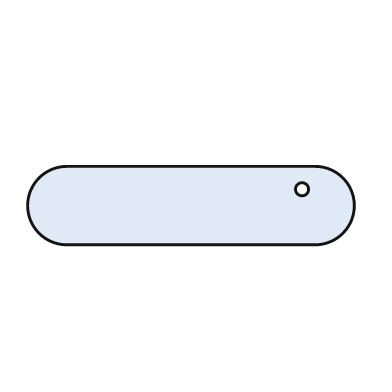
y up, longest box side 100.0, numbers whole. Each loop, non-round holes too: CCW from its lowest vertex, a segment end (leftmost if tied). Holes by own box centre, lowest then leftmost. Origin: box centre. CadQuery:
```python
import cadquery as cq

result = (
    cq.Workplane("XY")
    .moveTo(-38.0, -12.0)
    .lineTo(38.0, -12.0)
    .threePointArc((50.0, 0.0), (38.0, 12.0))
    .lineTo(-38.0, 12.0)
    .threePointArc((-50.0, 0.0), (-38.0, -12.0))
    .close()
    .moveTo(34.0, 5.0)
    .circle(2.0)
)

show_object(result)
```